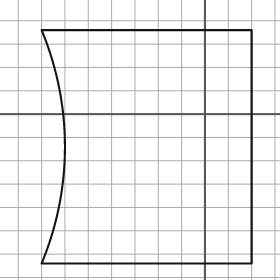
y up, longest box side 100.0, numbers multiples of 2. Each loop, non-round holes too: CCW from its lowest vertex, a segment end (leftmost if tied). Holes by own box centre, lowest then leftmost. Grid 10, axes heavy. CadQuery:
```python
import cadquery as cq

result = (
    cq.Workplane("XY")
    .moveTo(-70.0, -64.0)
    .lineTo(20.0, -64.0)
    .lineTo(20.0, 36.0)
    .lineTo(-70.0, 36.0)
    .threePointArc((-60.0, -14.0), (-70.0, -64.0))
    .close()
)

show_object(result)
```